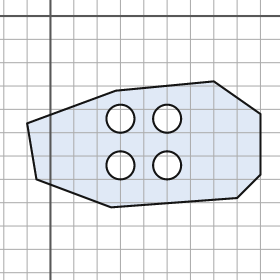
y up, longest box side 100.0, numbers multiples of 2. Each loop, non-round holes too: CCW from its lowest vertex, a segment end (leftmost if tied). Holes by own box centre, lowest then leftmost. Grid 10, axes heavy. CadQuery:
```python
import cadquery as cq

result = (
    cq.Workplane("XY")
    .moveTo(26.0, -82.0)
    .lineTo(80.0, -78.0)
    .lineTo(90.0, -68.0)
    .lineTo(90.0, -42.0)
    .lineTo(70.0, -28.0)
    .lineTo(28.0, -32.0)
    .lineTo(-10.0, -46.0)
    .lineTo(-6.0, -70.0)
    .close()
    .moveTo(30.0, -64.0)
    .circle(6.0)
    .moveTo(50.0, -64.0)
    .circle(6.0)
    .moveTo(30.0, -44.0)
    .circle(6.0)
    .moveTo(50.0, -44.0)
    .circle(6.0)
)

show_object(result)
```